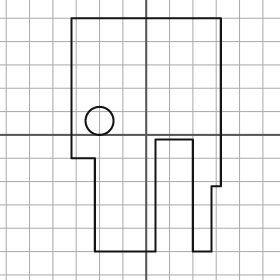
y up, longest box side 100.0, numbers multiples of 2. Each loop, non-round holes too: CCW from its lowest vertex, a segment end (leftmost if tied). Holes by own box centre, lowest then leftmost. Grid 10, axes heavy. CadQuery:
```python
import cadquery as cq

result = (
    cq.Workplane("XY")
    .moveTo(-22.0, -50.0)
    .lineTo(4.0, -50.0)
    .lineTo(4.0, -2.0)
    .lineTo(20.0, -2.0)
    .lineTo(20.0, -50.0)
    .lineTo(28.0, -50.0)
    .lineTo(28.0, -22.0)
    .lineTo(32.0, -22.0)
    .lineTo(32.0, 50.0)
    .lineTo(-32.0, 50.0)
    .lineTo(-32.0, -10.0)
    .lineTo(-22.0, -10.0)
    .close()
    .moveTo(-20.0, 6.0)
    .circle(6.0)
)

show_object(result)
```